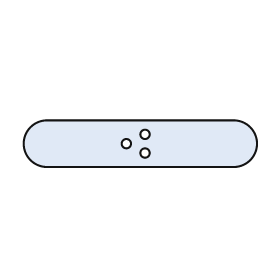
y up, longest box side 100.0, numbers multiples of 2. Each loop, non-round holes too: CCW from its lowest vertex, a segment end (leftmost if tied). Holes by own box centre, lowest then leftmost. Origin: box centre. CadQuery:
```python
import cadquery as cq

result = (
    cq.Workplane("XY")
    .moveTo(-40.0, -10.0)
    .lineTo(40.0, -10.0)
    .threePointArc((50.0, 0.0), (40.0, 10.0))
    .lineTo(-40.0, 10.0)
    .threePointArc((-50.0, 0.0), (-40.0, -10.0))
    .close()
    .moveTo(2.0, -4.0)
    .circle(2.0)
    .moveTo(-6.0, 0.0)
    .circle(2.0)
    .moveTo(2.0, 4.0)
    .circle(2.0)
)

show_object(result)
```